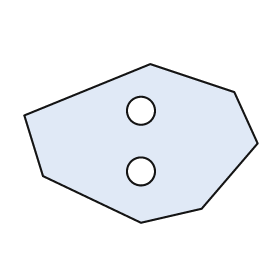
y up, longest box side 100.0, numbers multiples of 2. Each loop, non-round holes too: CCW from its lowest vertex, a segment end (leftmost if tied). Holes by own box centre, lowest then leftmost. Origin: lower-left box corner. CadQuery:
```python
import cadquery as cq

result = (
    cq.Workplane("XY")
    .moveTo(50.0, 0.0)
    .lineTo(76.0, 6.0)
    .lineTo(100.0, 34.0)
    .lineTo(90.0, 56.0)
    .lineTo(54.0, 68.0)
    .lineTo(0.0, 46.0)
    .lineTo(8.0, 20.0)
    .close()
    .moveTo(50.0, 22.0)
    .circle(6.0)
    .moveTo(50.0, 48.0)
    .circle(6.0)
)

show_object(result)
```